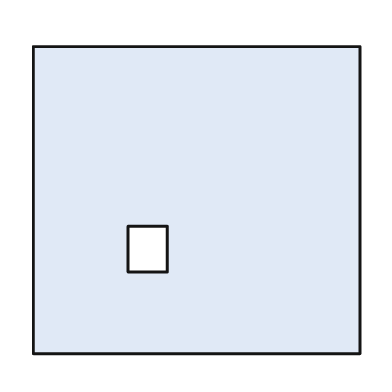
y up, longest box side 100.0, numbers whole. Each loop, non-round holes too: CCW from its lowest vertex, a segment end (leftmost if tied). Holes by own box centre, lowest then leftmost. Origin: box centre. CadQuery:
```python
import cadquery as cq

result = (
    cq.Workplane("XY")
    .moveTo(-50.0, -47.0)
    .lineTo(50.0, -47.0)
    .lineTo(50.0, 47.0)
    .lineTo(-50.0, 47.0)
    .close()
    .moveTo(-21.0, -22.0)
    .lineTo(-9.0, -22.0)
    .lineTo(-9.0, -8.0)
    .lineTo(-21.0, -8.0)
    .close()
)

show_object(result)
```